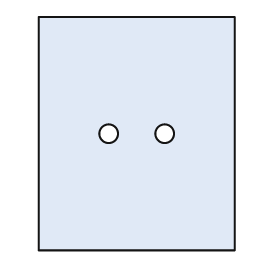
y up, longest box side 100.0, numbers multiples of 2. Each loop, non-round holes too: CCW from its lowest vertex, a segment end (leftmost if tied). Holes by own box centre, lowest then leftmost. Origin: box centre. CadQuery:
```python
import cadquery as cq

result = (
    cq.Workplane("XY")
    .moveTo(-42.0, -50.0)
    .lineTo(42.0, -50.0)
    .lineTo(42.0, 50.0)
    .lineTo(-42.0, 50.0)
    .close()
    .moveTo(-12.0, 0.0)
    .circle(4.0)
    .moveTo(12.0, 0.0)
    .circle(4.0)
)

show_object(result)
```